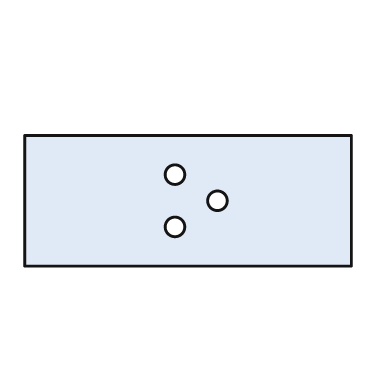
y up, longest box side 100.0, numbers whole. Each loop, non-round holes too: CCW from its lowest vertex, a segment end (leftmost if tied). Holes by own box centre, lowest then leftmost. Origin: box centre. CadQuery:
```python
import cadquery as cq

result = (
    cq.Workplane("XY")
    .moveTo(-50.0, -20.0)
    .lineTo(50.0, -20.0)
    .lineTo(50.0, 20.0)
    .lineTo(-50.0, 20.0)
    .close()
    .moveTo(-4.0, -8.0)
    .circle(3.0)
    .moveTo(9.0, 0.0)
    .circle(3.0)
    .moveTo(-4.0, 8.0)
    .circle(3.0)
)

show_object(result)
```